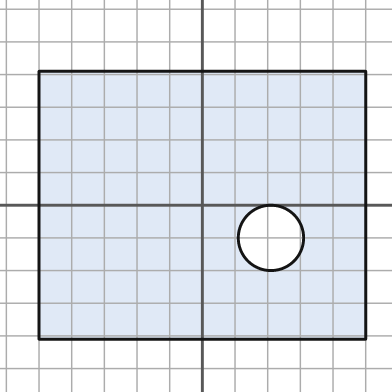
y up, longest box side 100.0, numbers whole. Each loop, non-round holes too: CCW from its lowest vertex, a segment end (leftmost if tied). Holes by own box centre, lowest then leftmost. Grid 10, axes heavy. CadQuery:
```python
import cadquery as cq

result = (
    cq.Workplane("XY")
    .moveTo(-50.0, -41.0)
    .lineTo(50.0, -41.0)
    .lineTo(50.0, 41.0)
    .lineTo(-50.0, 41.0)
    .close()
    .moveTo(21.0, -10.0)
    .circle(10.0)
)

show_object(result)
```